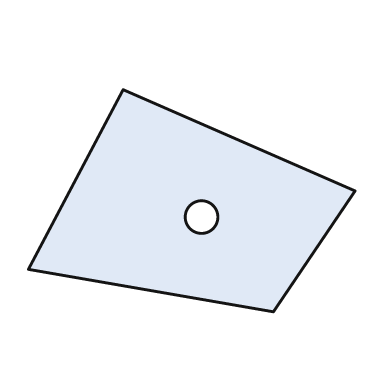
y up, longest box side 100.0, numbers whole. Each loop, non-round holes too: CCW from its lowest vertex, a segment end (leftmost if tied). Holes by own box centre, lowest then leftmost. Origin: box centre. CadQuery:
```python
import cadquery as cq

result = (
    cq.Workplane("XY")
    .moveTo(25.0, -34.0)
    .lineTo(50.0, 3.0)
    .lineTo(-21.0, 34.0)
    .lineTo(-50.0, -21.0)
    .close()
    .moveTo(3.0, -5.0)
    .circle(5.0)
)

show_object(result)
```